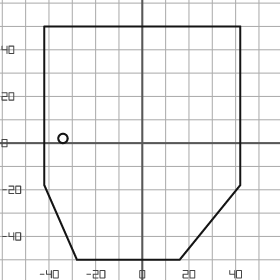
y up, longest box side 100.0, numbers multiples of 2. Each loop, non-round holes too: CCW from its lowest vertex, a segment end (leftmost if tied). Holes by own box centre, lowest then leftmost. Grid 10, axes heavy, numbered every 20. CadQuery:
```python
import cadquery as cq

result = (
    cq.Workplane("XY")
    .moveTo(-28.0, -50.0)
    .lineTo(16.0, -50.0)
    .lineTo(42.0, -18.0)
    .lineTo(42.0, 50.0)
    .lineTo(-42.0, 50.0)
    .lineTo(-42.0, -18.0)
    .close()
    .moveTo(-34.0, 2.0)
    .circle(2.0)
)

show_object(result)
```